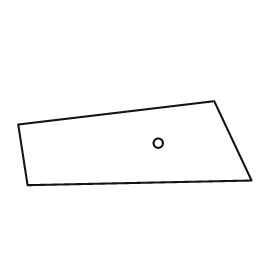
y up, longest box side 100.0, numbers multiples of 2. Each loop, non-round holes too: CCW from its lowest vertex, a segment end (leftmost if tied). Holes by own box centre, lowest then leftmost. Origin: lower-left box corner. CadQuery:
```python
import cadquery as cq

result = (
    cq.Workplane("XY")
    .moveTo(4.0, 0.0)
    .lineTo(100.0, 2.0)
    .lineTo(84.0, 36.0)
    .lineTo(0.0, 26.0)
    .close()
    .moveTo(60.0, 18.0)
    .circle(2.0)
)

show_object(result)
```